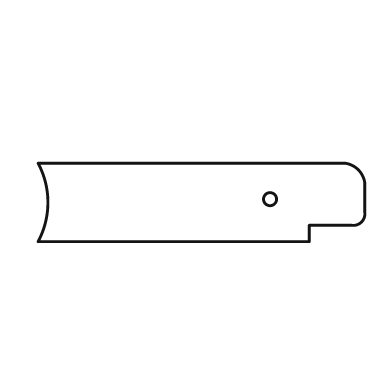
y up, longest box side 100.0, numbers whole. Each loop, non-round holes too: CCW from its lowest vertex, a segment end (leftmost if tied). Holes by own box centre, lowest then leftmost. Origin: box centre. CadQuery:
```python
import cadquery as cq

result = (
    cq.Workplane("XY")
    .moveTo(-50.0, -12.0)
    .lineTo(33.0, -12.0)
    .lineTo(33.0, -7.0)
    .lineTo(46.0, -7.0)
    .threePointArc((49.0, -6.0), (50.0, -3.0))
    .lineTo(50.0, 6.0)
    .threePointArc((48.0, 10.0), (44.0, 12.0))
    .lineTo(-50.0, 12.0)
    .threePointArc((-47.0, 0.0), (-50.0, -12.0))
    .close()
    .moveTo(21.0, 1.0)
    .circle(2.0)
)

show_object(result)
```